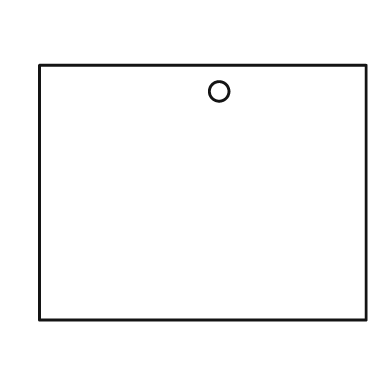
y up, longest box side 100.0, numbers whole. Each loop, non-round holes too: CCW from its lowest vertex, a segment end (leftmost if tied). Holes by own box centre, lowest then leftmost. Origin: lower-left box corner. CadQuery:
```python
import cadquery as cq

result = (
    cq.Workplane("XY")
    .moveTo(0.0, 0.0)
    .lineTo(100.0, 0.0)
    .lineTo(100.0, 78.0)
    .lineTo(0.0, 78.0)
    .close()
    .moveTo(55.0, 70.0)
    .circle(3.0)
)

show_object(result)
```